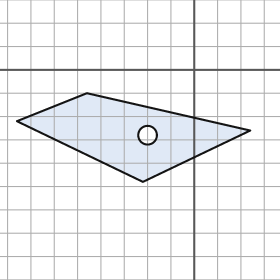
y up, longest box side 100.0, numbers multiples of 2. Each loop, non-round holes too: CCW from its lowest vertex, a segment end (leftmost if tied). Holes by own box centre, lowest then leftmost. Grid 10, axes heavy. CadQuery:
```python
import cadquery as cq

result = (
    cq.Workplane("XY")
    .moveTo(-22.0, -48.0)
    .lineTo(24.0, -26.0)
    .lineTo(-46.0, -10.0)
    .lineTo(-76.0, -22.0)
    .close()
    .moveTo(-20.0, -28.0)
    .circle(4.0)
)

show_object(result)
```